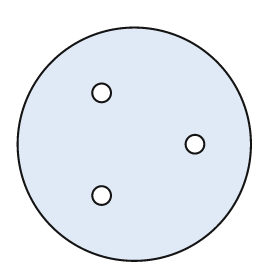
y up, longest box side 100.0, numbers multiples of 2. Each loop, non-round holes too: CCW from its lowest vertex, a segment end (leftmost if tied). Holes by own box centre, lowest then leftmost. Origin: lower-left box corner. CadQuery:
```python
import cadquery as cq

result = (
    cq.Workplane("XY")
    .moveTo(50.0, 50.0)
    .circle(50.0)
    .moveTo(36.0, 28.0)
    .circle(4.0)
    .moveTo(76.0, 50.0)
    .circle(4.0)
    .moveTo(36.0, 72.0)
    .circle(4.0)
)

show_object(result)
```